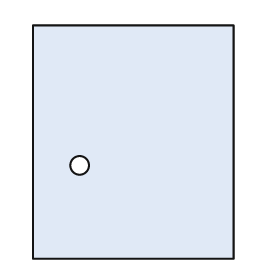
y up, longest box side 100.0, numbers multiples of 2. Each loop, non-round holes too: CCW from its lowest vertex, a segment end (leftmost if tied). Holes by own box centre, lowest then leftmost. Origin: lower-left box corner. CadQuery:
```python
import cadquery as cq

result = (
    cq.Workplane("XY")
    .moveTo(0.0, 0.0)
    .lineTo(86.0, 0.0)
    .lineTo(86.0, 100.0)
    .lineTo(0.0, 100.0)
    .close()
    .moveTo(20.0, 40.0)
    .circle(4.0)
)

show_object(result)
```